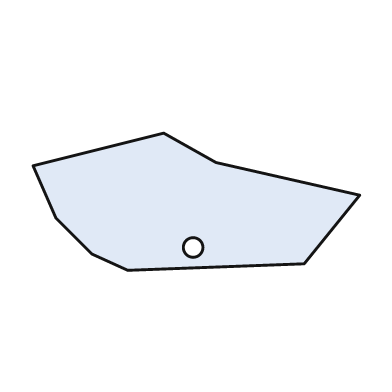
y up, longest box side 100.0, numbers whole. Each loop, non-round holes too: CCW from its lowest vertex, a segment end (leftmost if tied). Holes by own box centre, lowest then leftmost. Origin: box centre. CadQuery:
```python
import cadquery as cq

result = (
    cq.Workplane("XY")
    .moveTo(-21.0, -21.0)
    .lineTo(33.0, -19.0)
    .lineTo(50.0, 2.0)
    .lineTo(6.0, 12.0)
    .lineTo(-10.0, 21.0)
    .lineTo(-50.0, 11.0)
    .lineTo(-43.0, -5.0)
    .lineTo(-32.0, -16.0)
    .close()
    .moveTo(-1.0, -14.0)
    .circle(3.0)
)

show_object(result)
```